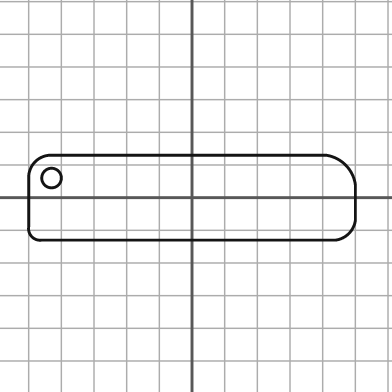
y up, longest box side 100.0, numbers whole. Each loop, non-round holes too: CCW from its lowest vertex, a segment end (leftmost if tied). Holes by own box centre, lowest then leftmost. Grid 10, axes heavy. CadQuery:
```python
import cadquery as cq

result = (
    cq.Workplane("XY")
    .moveTo(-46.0, -13.0)
    .lineTo(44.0, -13.0)
    .threePointArc((48.0, -11.0), (50.0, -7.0))
    .lineTo(50.0, 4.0)
    .threePointArc((47.0, 10.0), (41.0, 13.0))
    .lineTo(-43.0, 13.0)
    .threePointArc((-48.0, 11.0), (-50.0, 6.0))
    .lineTo(-50.0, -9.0)
    .threePointArc((-49.0, -12.0), (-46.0, -13.0))
    .close()
    .moveTo(-43.0, 6.0)
    .circle(3.0)
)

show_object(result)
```